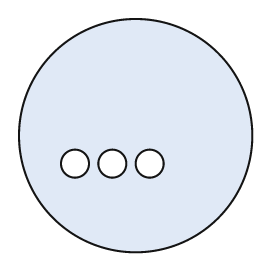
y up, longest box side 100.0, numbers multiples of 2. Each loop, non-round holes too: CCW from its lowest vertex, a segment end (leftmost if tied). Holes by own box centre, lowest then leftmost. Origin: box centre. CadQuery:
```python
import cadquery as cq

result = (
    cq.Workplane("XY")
    .moveTo(0.0, 0.0)
    .circle(50.0)
    .moveTo(-26.0, -12.0)
    .circle(6.0)
    .moveTo(-10.0, -12.0)
    .circle(6.0)
    .moveTo(6.0, -12.0)
    .circle(6.0)
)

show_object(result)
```